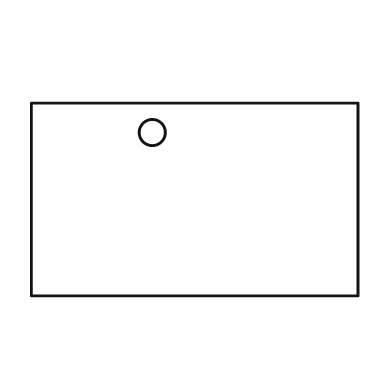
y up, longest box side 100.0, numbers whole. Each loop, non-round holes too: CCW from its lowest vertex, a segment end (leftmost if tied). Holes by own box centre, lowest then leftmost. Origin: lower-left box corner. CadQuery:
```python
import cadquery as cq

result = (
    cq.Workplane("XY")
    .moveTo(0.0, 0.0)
    .lineTo(100.0, 0.0)
    .lineTo(100.0, 59.0)
    .lineTo(0.0, 59.0)
    .close()
    .moveTo(37.0, 50.0)
    .circle(4.0)
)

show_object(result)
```